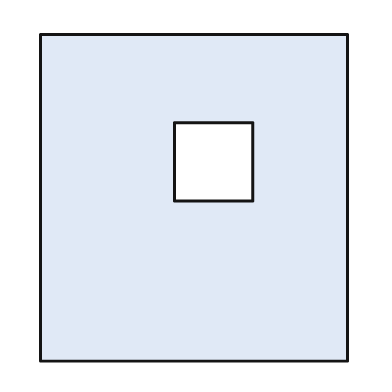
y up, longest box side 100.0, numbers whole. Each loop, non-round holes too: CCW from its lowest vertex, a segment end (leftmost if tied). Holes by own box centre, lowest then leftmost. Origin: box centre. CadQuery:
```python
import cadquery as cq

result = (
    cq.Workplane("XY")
    .moveTo(-47.0, -50.0)
    .lineTo(47.0, -50.0)
    .lineTo(47.0, 50.0)
    .lineTo(-47.0, 50.0)
    .close()
    .moveTo(-6.0, -1.0)
    .lineTo(18.0, -1.0)
    .lineTo(18.0, 23.0)
    .lineTo(-6.0, 23.0)
    .close()
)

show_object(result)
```